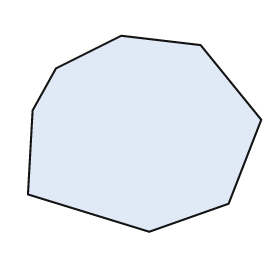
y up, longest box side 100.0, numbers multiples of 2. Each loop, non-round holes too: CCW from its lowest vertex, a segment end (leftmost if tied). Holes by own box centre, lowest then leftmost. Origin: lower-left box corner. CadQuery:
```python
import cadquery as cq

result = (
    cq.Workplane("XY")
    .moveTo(52.0, 0.0)
    .lineTo(86.0, 12.0)
    .lineTo(100.0, 48.0)
    .lineTo(74.0, 80.0)
    .lineTo(40.0, 84.0)
    .lineTo(12.0, 70.0)
    .lineTo(2.0, 52.0)
    .lineTo(0.0, 16.0)
    .close()
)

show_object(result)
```